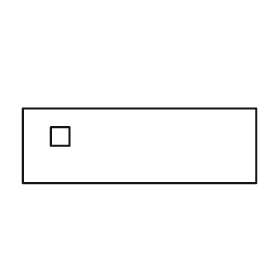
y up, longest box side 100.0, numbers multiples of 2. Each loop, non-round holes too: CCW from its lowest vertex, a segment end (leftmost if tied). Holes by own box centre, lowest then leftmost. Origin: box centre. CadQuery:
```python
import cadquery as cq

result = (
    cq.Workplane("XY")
    .moveTo(-50.0, -16.0)
    .lineTo(50.0, -16.0)
    .lineTo(50.0, 16.0)
    .lineTo(-50.0, 16.0)
    .close()
    .moveTo(-38.0, 0.0)
    .lineTo(-30.0, 0.0)
    .lineTo(-30.0, 8.0)
    .lineTo(-38.0, 8.0)
    .close()
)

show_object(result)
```